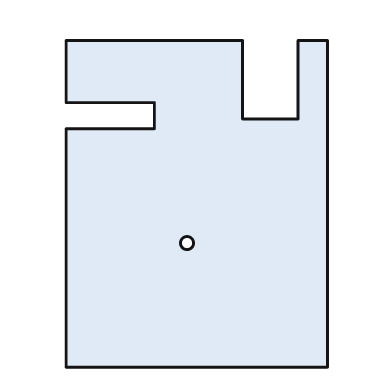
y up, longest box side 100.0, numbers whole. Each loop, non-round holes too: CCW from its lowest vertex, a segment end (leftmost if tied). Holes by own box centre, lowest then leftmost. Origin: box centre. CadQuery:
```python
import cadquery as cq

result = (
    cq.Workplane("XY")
    .moveTo(-40.0, -50.0)
    .lineTo(40.0, -50.0)
    .lineTo(40.0, 50.0)
    .lineTo(31.0, 50.0)
    .lineTo(31.0, 26.0)
    .lineTo(14.0, 26.0)
    .lineTo(14.0, 50.0)
    .lineTo(-40.0, 50.0)
    .lineTo(-40.0, 31.0)
    .lineTo(-13.0, 31.0)
    .lineTo(-13.0, 23.0)
    .lineTo(-40.0, 23.0)
    .close()
    .moveTo(-3.0, -12.0)
    .circle(2.0)
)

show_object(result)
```